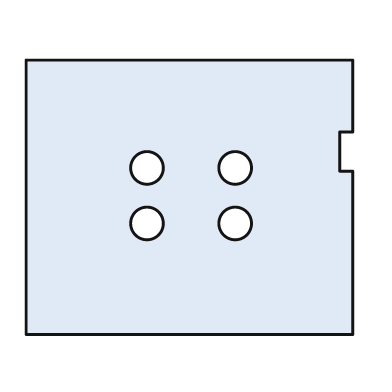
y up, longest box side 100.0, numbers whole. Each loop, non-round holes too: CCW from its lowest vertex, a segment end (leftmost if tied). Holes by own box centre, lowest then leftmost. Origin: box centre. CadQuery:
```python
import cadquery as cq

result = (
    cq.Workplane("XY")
    .moveTo(-50.0, -42.0)
    .lineTo(50.0, -42.0)
    .lineTo(50.0, 8.0)
    .lineTo(46.0, 8.0)
    .lineTo(46.0, 20.0)
    .lineTo(50.0, 20.0)
    .lineTo(50.0, 42.0)
    .lineTo(-50.0, 42.0)
    .close()
    .moveTo(-13.0, -8.0)
    .circle(5.0)
    .moveTo(14.0, -8.0)
    .circle(5.0)
    .moveTo(-13.0, 9.0)
    .circle(5.0)
    .moveTo(14.0, 9.0)
    .circle(5.0)
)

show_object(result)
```